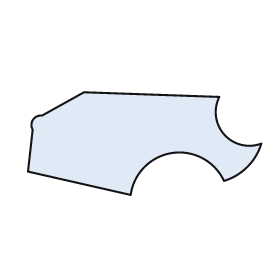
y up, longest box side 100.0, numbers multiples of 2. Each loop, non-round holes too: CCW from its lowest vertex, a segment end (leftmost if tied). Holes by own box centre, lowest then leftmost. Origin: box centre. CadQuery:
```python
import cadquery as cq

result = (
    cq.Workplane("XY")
    .moveTo(-6.0, -22.0)
    .threePointArc((12.0, -4.0), (34.0, -16.0))
    .threePointArc((44.0, -10.0), (50.0, 0.0))
    .threePointArc((34.0, 4.0), (32.0, 20.0))
    .lineTo(-26.0, 22.0)
    .lineTo(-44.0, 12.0)
    .threePointArc((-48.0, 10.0), (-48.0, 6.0))
    .lineTo(-50.0, -12.0)
    .close()
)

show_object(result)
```